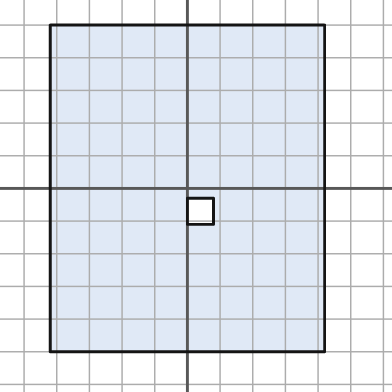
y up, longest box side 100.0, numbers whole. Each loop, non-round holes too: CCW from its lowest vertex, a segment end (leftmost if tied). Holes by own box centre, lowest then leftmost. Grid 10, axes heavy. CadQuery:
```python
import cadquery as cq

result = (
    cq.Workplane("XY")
    .moveTo(-42.0, -50.0)
    .lineTo(42.0, -50.0)
    .lineTo(42.0, 50.0)
    .lineTo(-42.0, 50.0)
    .close()
    .moveTo(0.0, -11.0)
    .lineTo(8.0, -11.0)
    .lineTo(8.0, -3.0)
    .lineTo(0.0, -3.0)
    .close()
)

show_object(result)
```